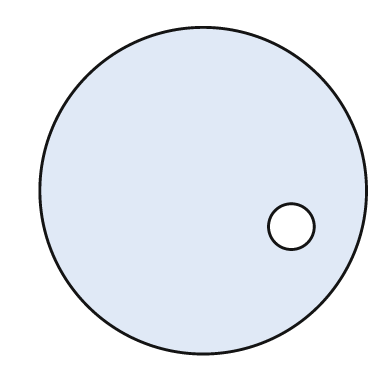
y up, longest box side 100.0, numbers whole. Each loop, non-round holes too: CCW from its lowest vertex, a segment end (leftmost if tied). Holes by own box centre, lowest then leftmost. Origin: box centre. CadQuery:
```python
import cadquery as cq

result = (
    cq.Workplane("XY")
    .moveTo(0.0, 0.0)
    .circle(50.0)
    .moveTo(27.0, -11.0)
    .circle(7.0)
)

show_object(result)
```